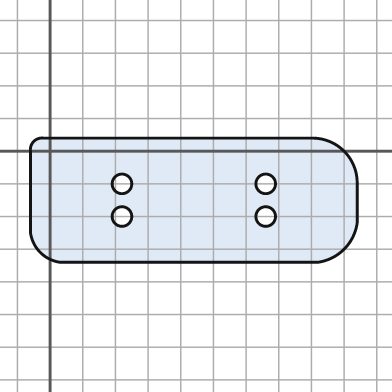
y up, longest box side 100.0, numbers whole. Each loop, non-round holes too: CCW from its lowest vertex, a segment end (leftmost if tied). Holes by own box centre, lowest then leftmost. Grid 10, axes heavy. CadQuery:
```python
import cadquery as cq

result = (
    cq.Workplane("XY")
    .moveTo(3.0, -34.0)
    .lineTo(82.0, -34.0)
    .threePointArc((90.0, -30.0), (94.0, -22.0))
    .lineTo(94.0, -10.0)
    .threePointArc((90.0, 0.0), (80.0, 4.0))
    .lineTo(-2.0, 4.0)
    .threePointArc((-5.0, 3.0), (-6.0, 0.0))
    .lineTo(-6.0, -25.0)
    .threePointArc((-3.0, -31.0), (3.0, -34.0))
    .close()
    .moveTo(22.0, -20.0)
    .circle(3.0)
    .moveTo(66.0, -20.0)
    .circle(3.0)
    .moveTo(22.0, -10.0)
    .circle(3.0)
    .moveTo(66.0, -10.0)
    .circle(3.0)
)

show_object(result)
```